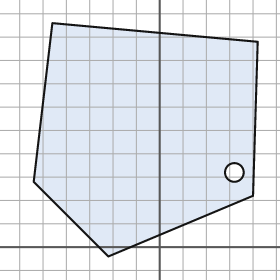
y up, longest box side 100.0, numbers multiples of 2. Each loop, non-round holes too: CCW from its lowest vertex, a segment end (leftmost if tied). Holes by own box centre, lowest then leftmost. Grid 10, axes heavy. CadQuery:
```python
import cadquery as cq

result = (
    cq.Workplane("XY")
    .moveTo(-22.0, -4.0)
    .lineTo(40.0, 22.0)
    .lineTo(42.0, 88.0)
    .lineTo(-46.0, 96.0)
    .lineTo(-54.0, 28.0)
    .close()
    .moveTo(32.0, 32.0)
    .circle(4.0)
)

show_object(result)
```